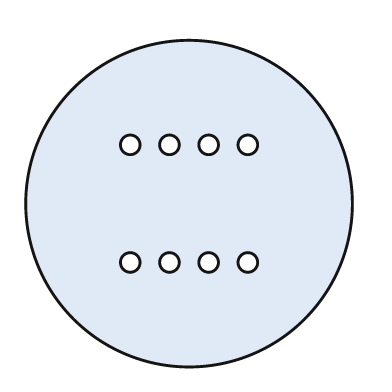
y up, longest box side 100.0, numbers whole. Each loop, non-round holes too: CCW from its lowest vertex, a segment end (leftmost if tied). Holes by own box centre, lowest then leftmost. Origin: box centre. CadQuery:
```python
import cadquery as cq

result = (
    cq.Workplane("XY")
    .moveTo(0.0, 0.0)
    .circle(50.0)
    .moveTo(-18.0, -18.0)
    .circle(3.0)
    .moveTo(-6.0, -18.0)
    .circle(3.0)
    .moveTo(6.0, -18.0)
    .circle(3.0)
    .moveTo(18.0, -18.0)
    .circle(3.0)
    .moveTo(-18.0, 18.0)
    .circle(3.0)
    .moveTo(-6.0, 18.0)
    .circle(3.0)
    .moveTo(6.0, 18.0)
    .circle(3.0)
    .moveTo(18.0, 18.0)
    .circle(3.0)
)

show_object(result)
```